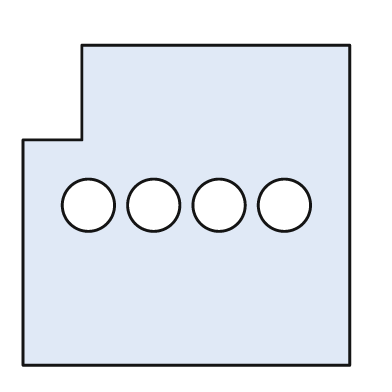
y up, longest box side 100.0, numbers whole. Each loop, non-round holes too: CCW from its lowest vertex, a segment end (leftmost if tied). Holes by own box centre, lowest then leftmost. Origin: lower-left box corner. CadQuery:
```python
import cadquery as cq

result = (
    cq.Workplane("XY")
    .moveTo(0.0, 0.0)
    .lineTo(100.0, 0.0)
    .lineTo(100.0, 98.0)
    .lineTo(18.0, 98.0)
    .lineTo(18.0, 69.0)
    .lineTo(0.0, 69.0)
    .close()
    .moveTo(20.0, 49.0)
    .circle(8.0)
    .moveTo(40.0, 49.0)
    .circle(8.0)
    .moveTo(60.0, 49.0)
    .circle(8.0)
    .moveTo(80.0, 49.0)
    .circle(8.0)
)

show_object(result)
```